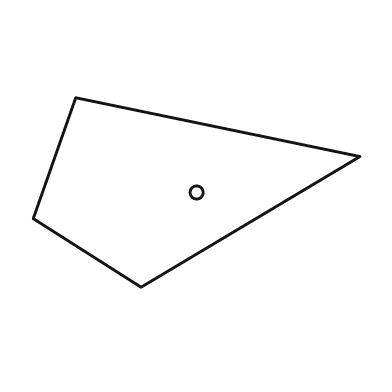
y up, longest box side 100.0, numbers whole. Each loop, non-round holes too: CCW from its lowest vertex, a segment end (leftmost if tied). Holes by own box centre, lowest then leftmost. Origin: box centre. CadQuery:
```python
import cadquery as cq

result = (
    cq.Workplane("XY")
    .moveTo(-17.0, -29.0)
    .lineTo(50.0, 11.0)
    .lineTo(-37.0, 29.0)
    .lineTo(-50.0, -8.0)
    .close()
    .moveTo(0.0, 0.0)
    .circle(2.0)
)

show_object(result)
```